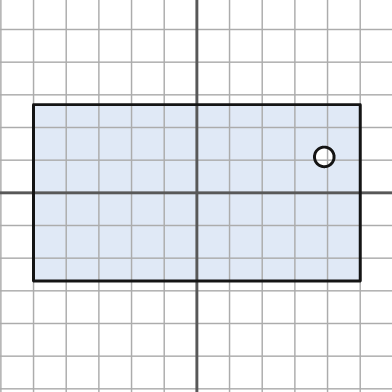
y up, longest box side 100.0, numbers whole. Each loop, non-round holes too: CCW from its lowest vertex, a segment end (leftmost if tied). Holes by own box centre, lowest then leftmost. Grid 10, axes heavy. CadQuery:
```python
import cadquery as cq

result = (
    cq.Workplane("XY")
    .moveTo(-50.0, -27.0)
    .lineTo(50.0, -27.0)
    .lineTo(50.0, 27.0)
    .lineTo(-50.0, 27.0)
    .close()
    .moveTo(39.0, 11.0)
    .circle(3.0)
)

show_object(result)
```